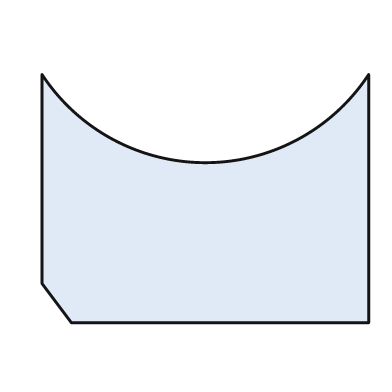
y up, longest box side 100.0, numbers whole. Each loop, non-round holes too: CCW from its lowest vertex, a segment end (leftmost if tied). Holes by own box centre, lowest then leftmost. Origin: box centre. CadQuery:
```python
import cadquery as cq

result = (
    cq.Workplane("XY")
    .moveTo(-41.0, -38.0)
    .lineTo(50.0, -38.0)
    .lineTo(50.0, 38.0)
    .threePointArc((0.0, 11.0), (-50.0, 38.0))
    .lineTo(-50.0, -26.0)
    .close()
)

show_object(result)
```